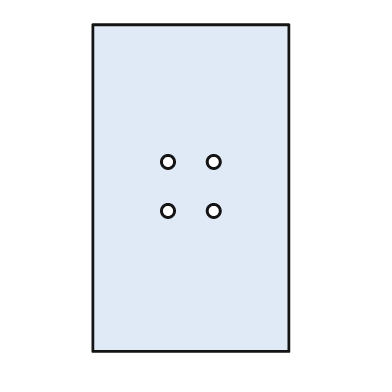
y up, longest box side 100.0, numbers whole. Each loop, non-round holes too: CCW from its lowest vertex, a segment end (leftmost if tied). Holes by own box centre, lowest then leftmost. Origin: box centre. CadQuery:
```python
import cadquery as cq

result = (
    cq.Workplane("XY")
    .moveTo(-30.0, -50.0)
    .lineTo(30.0, -50.0)
    .lineTo(30.0, 50.0)
    .lineTo(-30.0, 50.0)
    .close()
    .moveTo(-7.0, -7.0)
    .circle(2.0)
    .moveTo(7.0, -7.0)
    .circle(2.0)
    .moveTo(-7.0, 8.0)
    .circle(2.0)
    .moveTo(7.0, 8.0)
    .circle(2.0)
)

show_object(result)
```